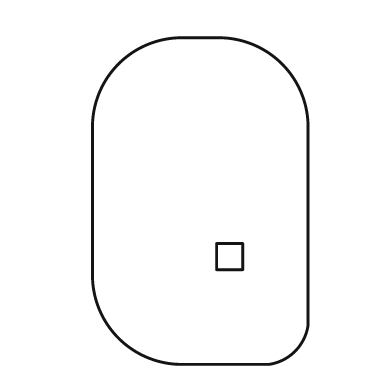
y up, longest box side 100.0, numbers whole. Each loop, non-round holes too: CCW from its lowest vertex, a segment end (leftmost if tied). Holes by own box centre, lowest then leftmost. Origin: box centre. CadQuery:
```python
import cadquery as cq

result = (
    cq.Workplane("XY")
    .moveTo(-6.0, -50.0)
    .lineTo(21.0, -50.0)
    .threePointArc((29.0, -46.0), (33.0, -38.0))
    .lineTo(33.0, 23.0)
    .threePointArc((25.0, 42.0), (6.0, 50.0))
    .lineTo(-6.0, 50.0)
    .threePointArc((-25.0, 42.0), (-33.0, 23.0))
    .lineTo(-33.0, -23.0)
    .threePointArc((-25.0, -42.0), (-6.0, -50.0))
    .close()
    .moveTo(5.0, -21.0)
    .lineTo(13.0, -21.0)
    .lineTo(13.0, -13.0)
    .lineTo(5.0, -13.0)
    .close()
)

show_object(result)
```